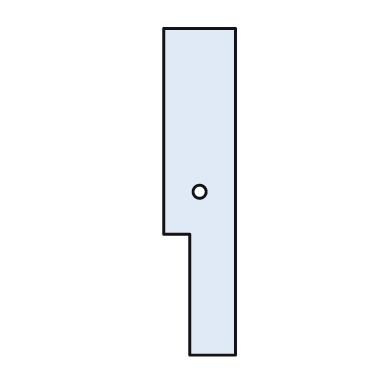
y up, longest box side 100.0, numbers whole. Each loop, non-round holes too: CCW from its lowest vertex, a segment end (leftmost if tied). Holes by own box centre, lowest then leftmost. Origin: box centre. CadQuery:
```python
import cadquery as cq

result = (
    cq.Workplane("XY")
    .moveTo(-3.0, -50.0)
    .lineTo(11.0, -50.0)
    .lineTo(11.0, 50.0)
    .lineTo(-11.0, 50.0)
    .lineTo(-11.0, -13.0)
    .lineTo(-3.0, -13.0)
    .close()
    .moveTo(0.0, 0.0)
    .circle(2.0)
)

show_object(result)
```